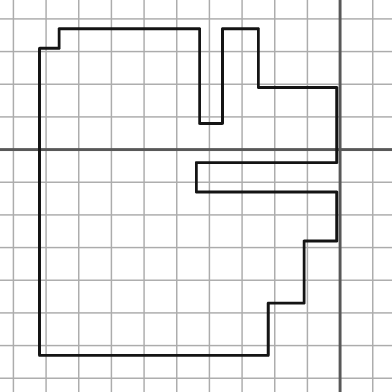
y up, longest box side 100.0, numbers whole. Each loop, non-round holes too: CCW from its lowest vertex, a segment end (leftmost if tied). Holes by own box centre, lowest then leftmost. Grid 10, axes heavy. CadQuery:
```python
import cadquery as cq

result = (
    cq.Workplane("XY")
    .moveTo(-92.0, -63.0)
    .lineTo(-22.0, -63.0)
    .lineTo(-22.0, -47.0)
    .lineTo(-11.0, -47.0)
    .lineTo(-11.0, -28.0)
    .lineTo(-1.0, -28.0)
    .lineTo(-1.0, -13.0)
    .lineTo(-44.0, -13.0)
    .lineTo(-44.0, -4.0)
    .lineTo(-1.0, -4.0)
    .lineTo(-1.0, 19.0)
    .lineTo(-25.0, 19.0)
    .lineTo(-25.0, 37.0)
    .lineTo(-36.0, 37.0)
    .lineTo(-36.0, 8.0)
    .lineTo(-43.0, 8.0)
    .lineTo(-43.0, 37.0)
    .lineTo(-86.0, 37.0)
    .lineTo(-86.0, 31.0)
    .lineTo(-92.0, 31.0)
    .close()
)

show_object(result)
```